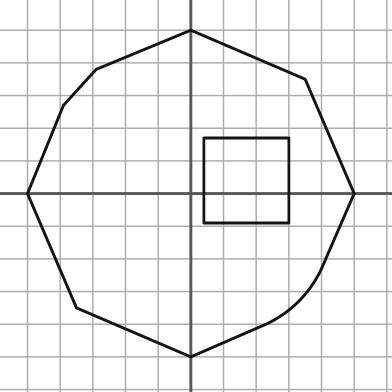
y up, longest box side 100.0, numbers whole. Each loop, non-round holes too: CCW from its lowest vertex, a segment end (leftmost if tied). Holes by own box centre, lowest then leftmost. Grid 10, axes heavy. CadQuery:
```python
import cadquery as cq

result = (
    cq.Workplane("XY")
    .moveTo(0.0, -50.0)
    .lineTo(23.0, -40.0)
    .threePointArc((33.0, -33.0), (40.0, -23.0))
    .lineTo(50.0, 0.0)
    .lineTo(35.0, 35.0)
    .lineTo(0.0, 50.0)
    .lineTo(-29.0, 38.0)
    .lineTo(-39.0, 27.0)
    .lineTo(-50.0, 0.0)
    .lineTo(-35.0, -35.0)
    .close()
    .moveTo(4.0, -9.0)
    .lineTo(30.0, -9.0)
    .lineTo(30.0, 17.0)
    .lineTo(4.0, 17.0)
    .close()
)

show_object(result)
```